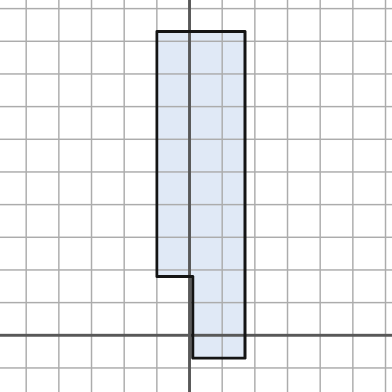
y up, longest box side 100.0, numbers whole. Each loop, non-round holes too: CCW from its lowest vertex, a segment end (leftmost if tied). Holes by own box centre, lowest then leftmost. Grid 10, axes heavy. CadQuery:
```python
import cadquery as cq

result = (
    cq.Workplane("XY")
    .moveTo(1.0, -7.0)
    .lineTo(17.0, -7.0)
    .lineTo(17.0, 93.0)
    .lineTo(-10.0, 93.0)
    .lineTo(-10.0, 18.0)
    .lineTo(1.0, 18.0)
    .close()
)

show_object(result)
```